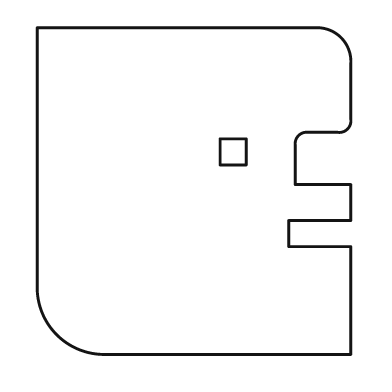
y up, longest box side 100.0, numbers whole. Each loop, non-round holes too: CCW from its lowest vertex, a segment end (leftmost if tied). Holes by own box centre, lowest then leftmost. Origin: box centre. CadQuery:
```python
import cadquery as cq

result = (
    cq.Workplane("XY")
    .moveTo(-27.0, -50.0)
    .lineTo(48.0, -50.0)
    .lineTo(48.0, -17.0)
    .lineTo(29.0, -17.0)
    .lineTo(29.0, -9.0)
    .lineTo(48.0, -9.0)
    .lineTo(48.0, 2.0)
    .lineTo(31.0, 2.0)
    .lineTo(31.0, 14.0)
    .threePointArc((32.0, 17.0), (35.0, 18.0))
    .lineTo(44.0, 18.0)
    .threePointArc((47.0, 19.0), (48.0, 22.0))
    .lineTo(48.0, 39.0)
    .threePointArc((45.0, 47.0), (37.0, 50.0))
    .lineTo(-48.0, 50.0)
    .lineTo(-48.0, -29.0)
    .threePointArc((-42.0, -44.0), (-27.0, -50.0))
    .close()
    .moveTo(8.0, 8.0)
    .lineTo(16.0, 8.0)
    .lineTo(16.0, 16.0)
    .lineTo(8.0, 16.0)
    .close()
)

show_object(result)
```